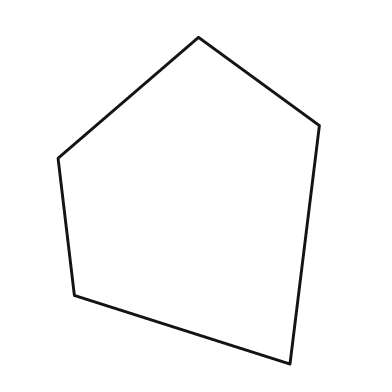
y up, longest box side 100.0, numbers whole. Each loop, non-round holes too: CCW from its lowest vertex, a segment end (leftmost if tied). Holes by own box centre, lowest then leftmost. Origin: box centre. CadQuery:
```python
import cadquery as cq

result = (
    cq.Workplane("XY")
    .moveTo(31.0, -50.0)
    .lineTo(40.0, 23.0)
    .lineTo(3.0, 50.0)
    .lineTo(-40.0, 13.0)
    .lineTo(-35.0, -29.0)
    .close()
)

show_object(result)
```